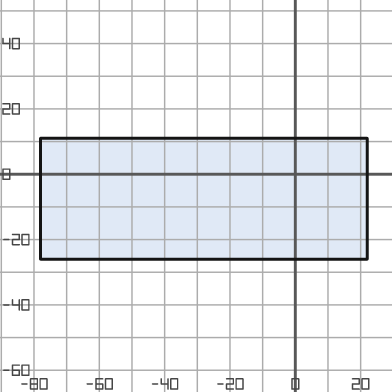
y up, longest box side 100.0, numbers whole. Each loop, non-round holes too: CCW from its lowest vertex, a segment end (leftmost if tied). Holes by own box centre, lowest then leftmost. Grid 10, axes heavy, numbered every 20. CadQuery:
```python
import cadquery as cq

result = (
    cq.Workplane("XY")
    .moveTo(-78.0, -26.0)
    .lineTo(22.0, -26.0)
    .lineTo(22.0, 11.0)
    .lineTo(-78.0, 11.0)
    .close()
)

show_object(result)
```